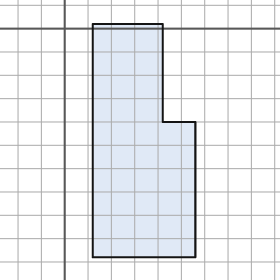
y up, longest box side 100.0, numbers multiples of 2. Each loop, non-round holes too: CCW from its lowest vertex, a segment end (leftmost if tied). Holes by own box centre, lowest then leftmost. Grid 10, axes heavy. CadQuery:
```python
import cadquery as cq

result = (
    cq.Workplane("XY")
    .moveTo(12.0, -98.0)
    .lineTo(56.0, -98.0)
    .lineTo(56.0, -40.0)
    .lineTo(42.0, -40.0)
    .lineTo(42.0, 2.0)
    .lineTo(12.0, 2.0)
    .close()
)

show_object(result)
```